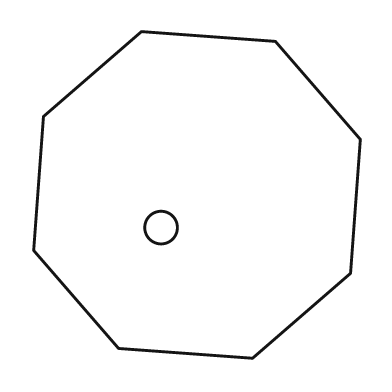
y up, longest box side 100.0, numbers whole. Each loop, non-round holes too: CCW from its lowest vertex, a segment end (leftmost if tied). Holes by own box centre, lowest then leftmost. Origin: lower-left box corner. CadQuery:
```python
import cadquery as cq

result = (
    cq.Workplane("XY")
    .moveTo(67.0, 0.0)
    .lineTo(97.0, 26.0)
    .lineTo(100.0, 67.0)
    .lineTo(74.0, 97.0)
    .lineTo(33.0, 100.0)
    .lineTo(3.0, 74.0)
    .lineTo(0.0, 33.0)
    .lineTo(26.0, 3.0)
    .close()
    .moveTo(39.0, 40.0)
    .circle(5.0)
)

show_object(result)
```